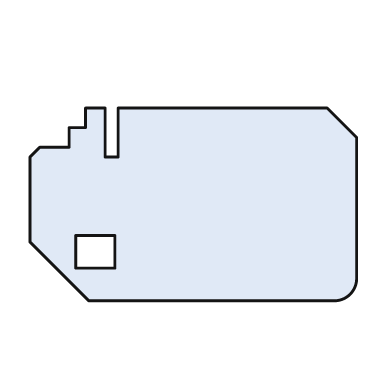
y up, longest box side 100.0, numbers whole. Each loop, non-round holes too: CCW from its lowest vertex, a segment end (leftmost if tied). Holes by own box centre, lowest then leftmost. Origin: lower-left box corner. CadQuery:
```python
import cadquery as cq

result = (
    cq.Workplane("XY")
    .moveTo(18.0, 0.0)
    .lineTo(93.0, 0.0)
    .threePointArc((98.0, 2.0), (100.0, 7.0))
    .lineTo(100.0, 50.0)
    .lineTo(91.0, 59.0)
    .lineTo(27.0, 59.0)
    .lineTo(27.0, 44.0)
    .lineTo(23.0, 44.0)
    .lineTo(23.0, 59.0)
    .lineTo(17.0, 59.0)
    .lineTo(17.0, 53.0)
    .lineTo(12.0, 53.0)
    .lineTo(12.0, 47.0)
    .lineTo(3.0, 47.0)
    .lineTo(0.0, 44.0)
    .lineTo(0.0, 18.0)
    .close()
    .moveTo(14.0, 10.0)
    .lineTo(26.0, 10.0)
    .lineTo(26.0, 20.0)
    .lineTo(14.0, 20.0)
    .close()
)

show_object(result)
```